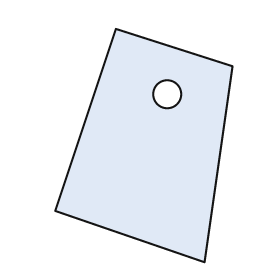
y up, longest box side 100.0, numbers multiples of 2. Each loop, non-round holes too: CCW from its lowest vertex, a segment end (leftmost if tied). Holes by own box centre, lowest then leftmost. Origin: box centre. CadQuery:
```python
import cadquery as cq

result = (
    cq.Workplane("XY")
    .moveTo(26.0, -50.0)
    .lineTo(38.0, 34.0)
    .lineTo(-12.0, 50.0)
    .lineTo(-38.0, -28.0)
    .close()
    .moveTo(10.0, 22.0)
    .circle(6.0)
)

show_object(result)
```